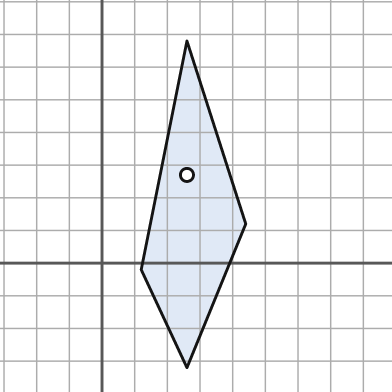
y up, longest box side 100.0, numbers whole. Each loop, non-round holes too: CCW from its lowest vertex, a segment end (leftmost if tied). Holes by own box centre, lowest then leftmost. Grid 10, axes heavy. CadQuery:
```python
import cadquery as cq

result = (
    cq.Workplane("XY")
    .moveTo(26.0, -32.0)
    .lineTo(44.0, 12.0)
    .lineTo(26.0, 68.0)
    .lineTo(12.0, -2.0)
    .close()
    .moveTo(26.0, 27.0)
    .circle(2.0)
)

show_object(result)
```